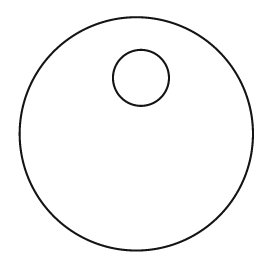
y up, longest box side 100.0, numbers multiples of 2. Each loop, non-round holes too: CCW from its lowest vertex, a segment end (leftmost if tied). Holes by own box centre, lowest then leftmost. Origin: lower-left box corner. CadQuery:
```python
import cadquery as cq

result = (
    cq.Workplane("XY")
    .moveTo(50.0, 50.0)
    .circle(50.0)
    .moveTo(52.0, 74.0)
    .circle(12.0)
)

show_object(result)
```